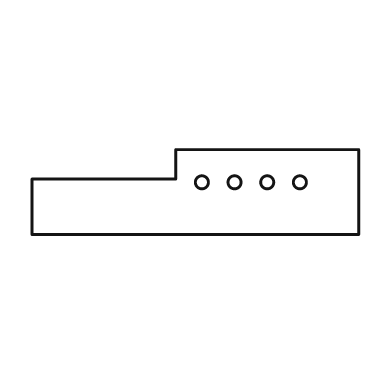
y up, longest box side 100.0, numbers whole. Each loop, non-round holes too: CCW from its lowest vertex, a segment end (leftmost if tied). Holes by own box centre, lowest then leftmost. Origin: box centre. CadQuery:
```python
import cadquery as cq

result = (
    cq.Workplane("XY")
    .moveTo(-50.0, -13.0)
    .lineTo(50.0, -13.0)
    .lineTo(50.0, 13.0)
    .lineTo(-6.0, 13.0)
    .lineTo(-6.0, 4.0)
    .lineTo(-50.0, 4.0)
    .close()
    .moveTo(2.0, 3.0)
    .circle(2.0)
    .moveTo(12.0, 3.0)
    .circle(2.0)
    .moveTo(22.0, 3.0)
    .circle(2.0)
    .moveTo(32.0, 3.0)
    .circle(2.0)
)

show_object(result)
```